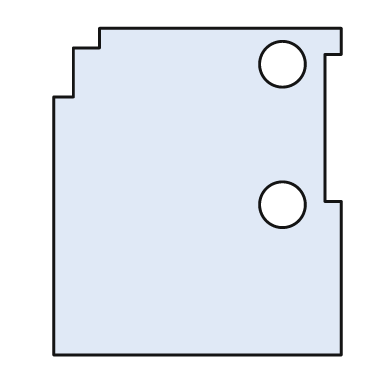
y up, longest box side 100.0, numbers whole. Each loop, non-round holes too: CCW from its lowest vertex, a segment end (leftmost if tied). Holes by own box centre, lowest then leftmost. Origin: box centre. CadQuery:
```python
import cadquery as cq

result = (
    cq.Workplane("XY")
    .moveTo(-44.0, -50.0)
    .lineTo(44.0, -50.0)
    .lineTo(44.0, -3.0)
    .lineTo(39.0, -3.0)
    .lineTo(39.0, 42.0)
    .lineTo(44.0, 42.0)
    .lineTo(44.0, 50.0)
    .lineTo(-30.0, 50.0)
    .lineTo(-30.0, 44.0)
    .lineTo(-38.0, 44.0)
    .lineTo(-38.0, 29.0)
    .lineTo(-44.0, 29.0)
    .close()
    .moveTo(26.0, -4.0)
    .circle(7.0)
    .moveTo(26.0, 39.0)
    .circle(7.0)
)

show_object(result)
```